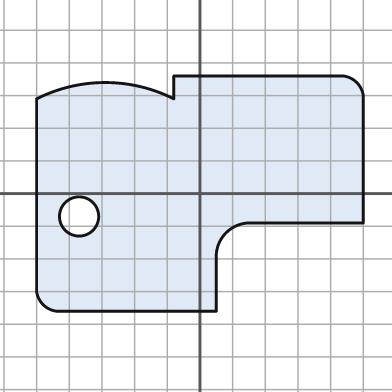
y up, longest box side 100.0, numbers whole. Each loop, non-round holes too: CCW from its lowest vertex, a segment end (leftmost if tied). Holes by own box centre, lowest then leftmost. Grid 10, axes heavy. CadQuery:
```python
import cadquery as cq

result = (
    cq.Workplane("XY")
    .moveTo(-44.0, -36.0)
    .lineTo(5.0, -36.0)
    .lineTo(5.0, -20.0)
    .threePointArc((8.0, -12.0), (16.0, -9.0))
    .lineTo(50.0, -9.0)
    .lineTo(50.0, 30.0)
    .threePointArc((48.0, 34.0), (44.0, 36.0))
    .lineTo(-8.0, 36.0)
    .lineTo(-8.0, 29.0)
    .threePointArc((-29.0, 34.0), (-50.0, 29.0))
    .lineTo(-50.0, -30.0)
    .threePointArc((-48.0, -34.0), (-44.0, -36.0))
    .close()
    .moveTo(-37.0, -7.0)
    .circle(6.0)
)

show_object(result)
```